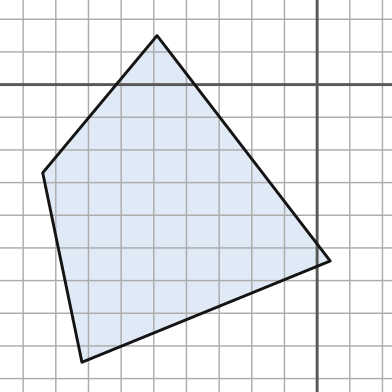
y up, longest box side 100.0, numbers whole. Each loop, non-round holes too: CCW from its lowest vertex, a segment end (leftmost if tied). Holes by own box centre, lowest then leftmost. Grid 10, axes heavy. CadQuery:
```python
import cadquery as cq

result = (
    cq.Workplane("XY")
    .moveTo(-72.0, -85.0)
    .lineTo(4.0, -54.0)
    .lineTo(-49.0, 15.0)
    .lineTo(-84.0, -27.0)
    .close()
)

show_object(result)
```